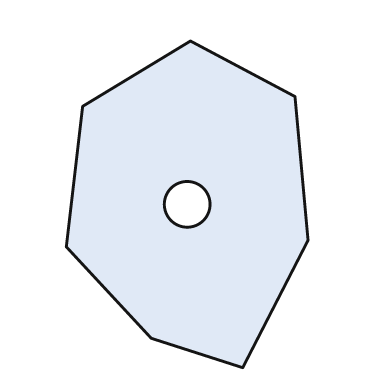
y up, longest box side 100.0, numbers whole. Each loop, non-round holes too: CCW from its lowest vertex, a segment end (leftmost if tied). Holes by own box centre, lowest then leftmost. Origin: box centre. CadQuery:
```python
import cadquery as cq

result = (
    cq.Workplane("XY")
    .moveTo(17.0, -50.0)
    .lineTo(37.0, -11.0)
    .lineTo(33.0, 33.0)
    .lineTo(1.0, 50.0)
    .lineTo(-32.0, 30.0)
    .lineTo(-37.0, -13.0)
    .lineTo(-11.0, -41.0)
    .close()
    .moveTo(0.0, 0.0)
    .circle(7.0)
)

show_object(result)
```